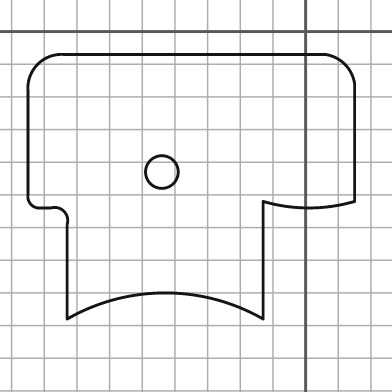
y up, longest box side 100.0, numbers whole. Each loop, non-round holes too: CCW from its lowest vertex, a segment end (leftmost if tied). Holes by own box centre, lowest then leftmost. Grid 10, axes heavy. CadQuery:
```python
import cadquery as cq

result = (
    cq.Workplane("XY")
    .moveTo(-73.0, -88.0)
    .threePointArc((-43.0, -80.0), (-13.0, -88.0))
    .lineTo(-13.0, -52.0)
    .threePointArc((1.0, -54.0), (15.0, -52.0))
    .lineTo(15.0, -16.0)
    .threePointArc((12.0, -10.0), (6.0, -7.0))
    .lineTo(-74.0, -7.0)
    .threePointArc((-82.0, -10.0), (-85.0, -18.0))
    .lineTo(-85.0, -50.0)
    .threePointArc((-84.0, -53.0), (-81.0, -54.0))
    .lineTo(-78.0, -54.0)
    .threePointArc((-74.0, -55.0), (-73.0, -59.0))
    .close()
    .moveTo(-44.0, -43.0)
    .circle(5.0)
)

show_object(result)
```